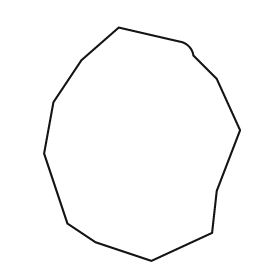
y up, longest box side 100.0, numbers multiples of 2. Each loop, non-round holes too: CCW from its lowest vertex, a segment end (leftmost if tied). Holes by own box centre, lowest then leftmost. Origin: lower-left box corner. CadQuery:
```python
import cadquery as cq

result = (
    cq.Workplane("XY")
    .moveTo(46.0, 0.0)
    .lineTo(72.0, 12.0)
    .lineTo(74.0, 30.0)
    .lineTo(84.0, 56.0)
    .lineTo(74.0, 78.0)
    .lineTo(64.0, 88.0)
    .threePointArc((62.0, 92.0), (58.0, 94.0))
    .lineTo(32.0, 100.0)
    .lineTo(16.0, 86.0)
    .lineTo(4.0, 68.0)
    .lineTo(0.0, 46.0)
    .lineTo(10.0, 16.0)
    .lineTo(22.0, 8.0)
    .close()
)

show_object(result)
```